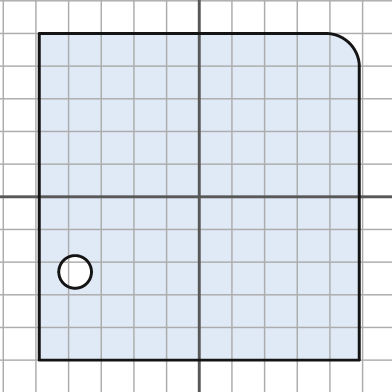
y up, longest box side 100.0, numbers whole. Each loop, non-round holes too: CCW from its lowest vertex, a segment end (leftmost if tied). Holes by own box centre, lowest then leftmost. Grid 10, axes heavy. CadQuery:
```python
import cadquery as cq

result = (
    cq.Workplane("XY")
    .moveTo(-49.0, -50.0)
    .lineTo(49.0, -50.0)
    .lineTo(49.0, 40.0)
    .threePointArc((46.0, 47.0), (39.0, 50.0))
    .lineTo(-49.0, 50.0)
    .close()
    .moveTo(-38.0, -23.0)
    .circle(5.0)
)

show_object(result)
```